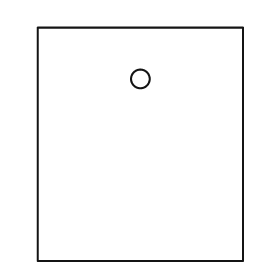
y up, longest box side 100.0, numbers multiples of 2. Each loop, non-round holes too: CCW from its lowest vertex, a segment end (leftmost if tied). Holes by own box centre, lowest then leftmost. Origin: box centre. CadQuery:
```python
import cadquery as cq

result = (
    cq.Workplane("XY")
    .moveTo(-44.0, -50.0)
    .lineTo(44.0, -50.0)
    .lineTo(44.0, 50.0)
    .lineTo(-44.0, 50.0)
    .close()
    .moveTo(0.0, 28.0)
    .circle(4.0)
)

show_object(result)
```